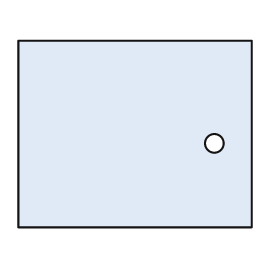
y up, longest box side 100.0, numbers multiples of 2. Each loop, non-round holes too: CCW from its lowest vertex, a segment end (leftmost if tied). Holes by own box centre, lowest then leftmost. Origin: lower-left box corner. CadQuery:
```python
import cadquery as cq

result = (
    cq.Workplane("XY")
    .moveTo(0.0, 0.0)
    .lineTo(100.0, 0.0)
    .lineTo(100.0, 80.0)
    .lineTo(0.0, 80.0)
    .close()
    .moveTo(84.0, 36.0)
    .circle(4.0)
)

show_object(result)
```